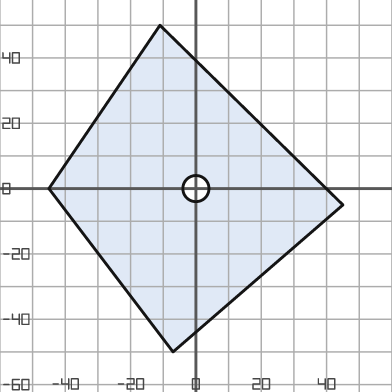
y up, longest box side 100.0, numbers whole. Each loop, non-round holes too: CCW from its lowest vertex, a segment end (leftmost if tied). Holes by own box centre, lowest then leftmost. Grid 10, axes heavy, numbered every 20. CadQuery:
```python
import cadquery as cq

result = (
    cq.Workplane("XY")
    .moveTo(-7.0, -50.0)
    .lineTo(45.0, -5.0)
    .lineTo(-11.0, 50.0)
    .lineTo(-45.0, 0.0)
    .close()
    .moveTo(0.0, 0.0)
    .circle(4.0)
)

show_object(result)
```